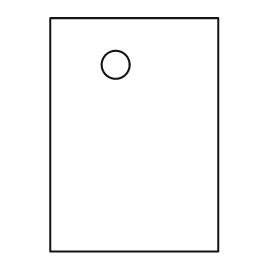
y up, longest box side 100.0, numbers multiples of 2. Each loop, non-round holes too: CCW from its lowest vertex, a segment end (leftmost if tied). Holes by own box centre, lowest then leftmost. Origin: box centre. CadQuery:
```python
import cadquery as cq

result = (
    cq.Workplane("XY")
    .moveTo(-36.0, -50.0)
    .lineTo(36.0, -50.0)
    .lineTo(36.0, 50.0)
    .lineTo(-36.0, 50.0)
    .close()
    .moveTo(-8.0, 30.0)
    .circle(6.0)
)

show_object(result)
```